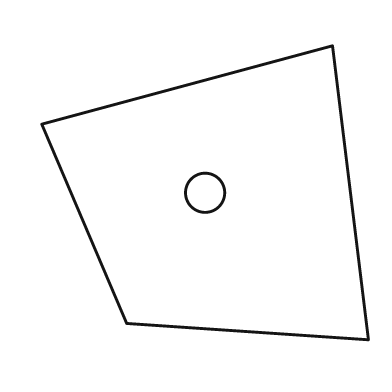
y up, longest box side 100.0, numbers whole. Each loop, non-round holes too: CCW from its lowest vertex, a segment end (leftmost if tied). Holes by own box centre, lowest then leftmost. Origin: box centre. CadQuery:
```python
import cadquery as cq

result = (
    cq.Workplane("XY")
    .moveTo(50.0, -45.0)
    .lineTo(39.0, 45.0)
    .lineTo(-50.0, 21.0)
    .lineTo(-24.0, -40.0)
    .close()
    .moveTo(0.0, 0.0)
    .circle(6.0)
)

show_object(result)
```